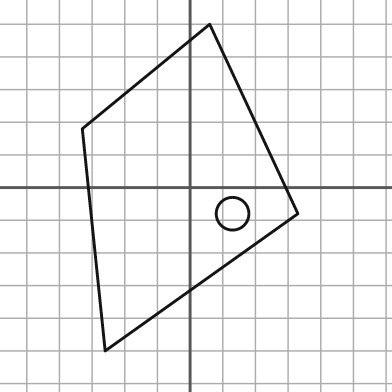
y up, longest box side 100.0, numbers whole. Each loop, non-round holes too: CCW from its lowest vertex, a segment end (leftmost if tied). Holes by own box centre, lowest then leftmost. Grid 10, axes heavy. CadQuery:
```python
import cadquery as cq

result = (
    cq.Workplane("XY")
    .moveTo(-26.0, -50.0)
    .lineTo(33.0, -8.0)
    .lineTo(6.0, 50.0)
    .lineTo(-33.0, 18.0)
    .close()
    .moveTo(13.0, -8.0)
    .circle(5.0)
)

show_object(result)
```